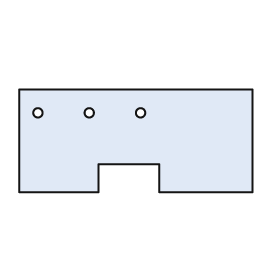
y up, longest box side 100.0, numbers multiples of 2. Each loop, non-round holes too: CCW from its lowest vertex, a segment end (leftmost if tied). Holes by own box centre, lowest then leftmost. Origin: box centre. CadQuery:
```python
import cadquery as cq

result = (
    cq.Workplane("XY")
    .moveTo(-50.0, -22.0)
    .lineTo(-16.0, -22.0)
    .lineTo(-16.0, -10.0)
    .lineTo(10.0, -10.0)
    .lineTo(10.0, -22.0)
    .lineTo(50.0, -22.0)
    .lineTo(50.0, 22.0)
    .lineTo(-50.0, 22.0)
    .close()
    .moveTo(-42.0, 12.0)
    .circle(2.0)
    .moveTo(-20.0, 12.0)
    .circle(2.0)
    .moveTo(2.0, 12.0)
    .circle(2.0)
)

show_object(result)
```